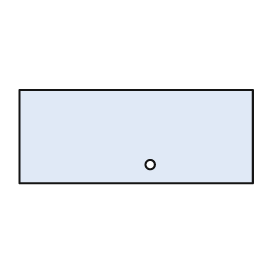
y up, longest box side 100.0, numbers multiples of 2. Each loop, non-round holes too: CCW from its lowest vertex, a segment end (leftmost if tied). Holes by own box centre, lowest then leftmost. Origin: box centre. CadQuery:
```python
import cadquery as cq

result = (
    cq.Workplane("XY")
    .moveTo(-50.0, -20.0)
    .lineTo(50.0, -20.0)
    .lineTo(50.0, 20.0)
    .lineTo(-50.0, 20.0)
    .close()
    .moveTo(6.0, -12.0)
    .circle(2.0)
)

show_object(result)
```